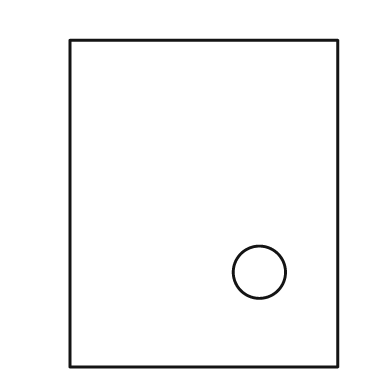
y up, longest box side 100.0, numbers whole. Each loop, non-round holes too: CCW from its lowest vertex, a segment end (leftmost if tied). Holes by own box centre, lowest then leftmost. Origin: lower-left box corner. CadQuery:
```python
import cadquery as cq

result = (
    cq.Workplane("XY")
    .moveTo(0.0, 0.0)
    .lineTo(82.0, 0.0)
    .lineTo(82.0, 100.0)
    .lineTo(0.0, 100.0)
    .close()
    .moveTo(58.0, 29.0)
    .circle(8.0)
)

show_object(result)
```